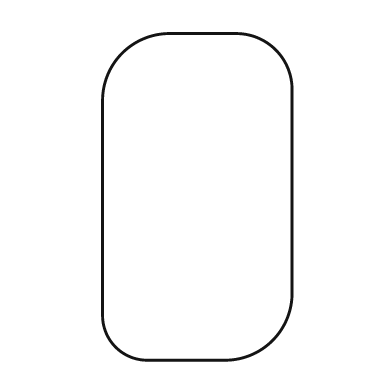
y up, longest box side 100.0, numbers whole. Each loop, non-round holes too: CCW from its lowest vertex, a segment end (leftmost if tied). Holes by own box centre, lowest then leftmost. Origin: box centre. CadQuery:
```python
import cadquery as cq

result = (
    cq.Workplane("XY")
    .moveTo(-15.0, -50.0)
    .lineTo(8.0, -50.0)
    .threePointArc((23.0, -44.0), (29.0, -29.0))
    .lineTo(29.0, 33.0)
    .threePointArc((24.0, 45.0), (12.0, 50.0))
    .lineTo(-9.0, 50.0)
    .threePointArc((-23.0, 44.0), (-29.0, 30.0))
    .lineTo(-29.0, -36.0)
    .threePointArc((-25.0, -46.0), (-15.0, -50.0))
    .close()
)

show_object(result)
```